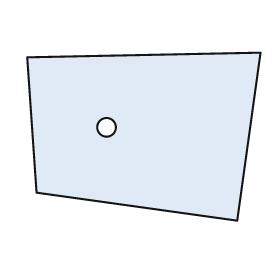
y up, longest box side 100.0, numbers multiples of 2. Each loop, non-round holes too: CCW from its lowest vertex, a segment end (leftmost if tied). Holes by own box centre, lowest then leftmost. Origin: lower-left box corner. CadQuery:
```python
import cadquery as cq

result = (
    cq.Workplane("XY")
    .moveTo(90.0, 0.0)
    .lineTo(100.0, 72.0)
    .lineTo(0.0, 70.0)
    .lineTo(4.0, 12.0)
    .close()
    .moveTo(34.0, 40.0)
    .circle(4.0)
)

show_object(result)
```